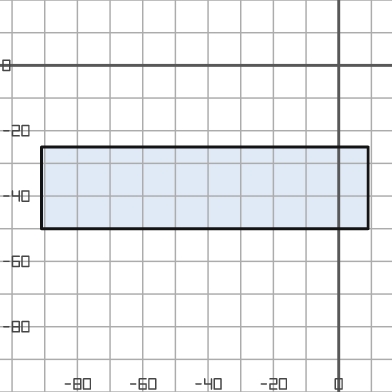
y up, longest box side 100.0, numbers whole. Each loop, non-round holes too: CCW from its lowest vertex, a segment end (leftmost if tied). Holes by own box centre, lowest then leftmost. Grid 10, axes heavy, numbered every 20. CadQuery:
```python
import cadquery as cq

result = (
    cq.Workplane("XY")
    .moveTo(-91.0, -50.0)
    .lineTo(9.0, -50.0)
    .lineTo(9.0, -25.0)
    .lineTo(-91.0, -25.0)
    .close()
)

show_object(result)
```